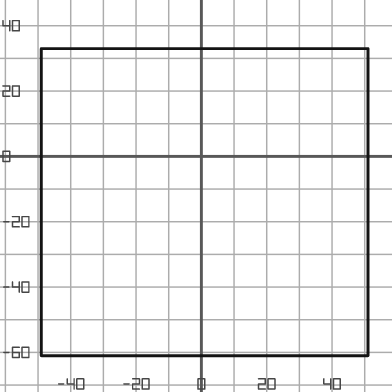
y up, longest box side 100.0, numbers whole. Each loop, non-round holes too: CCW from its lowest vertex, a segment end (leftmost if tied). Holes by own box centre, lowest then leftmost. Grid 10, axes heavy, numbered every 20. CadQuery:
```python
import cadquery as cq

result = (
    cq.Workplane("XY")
    .moveTo(-49.0, -61.0)
    .lineTo(51.0, -61.0)
    .lineTo(51.0, 33.0)
    .lineTo(-49.0, 33.0)
    .close()
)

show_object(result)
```